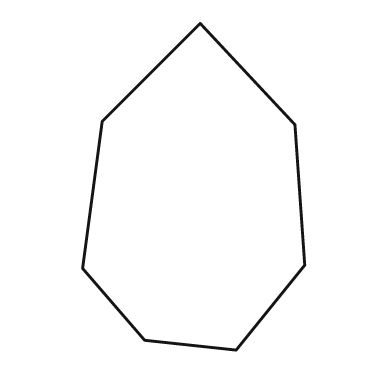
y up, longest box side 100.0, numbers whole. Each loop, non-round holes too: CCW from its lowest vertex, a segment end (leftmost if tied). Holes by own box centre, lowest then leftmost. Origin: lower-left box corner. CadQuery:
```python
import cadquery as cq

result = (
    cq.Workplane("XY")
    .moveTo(47.0, 0.0)
    .lineTo(68.0, 26.0)
    .lineTo(65.0, 69.0)
    .lineTo(36.0, 100.0)
    .lineTo(6.0, 70.0)
    .lineTo(0.0, 25.0)
    .lineTo(19.0, 3.0)
    .close()
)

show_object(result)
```